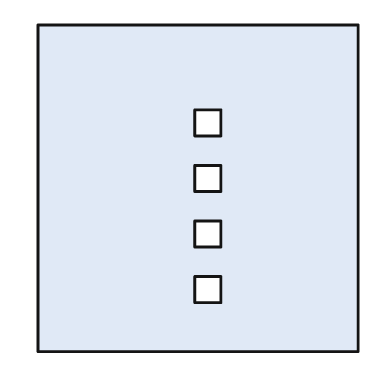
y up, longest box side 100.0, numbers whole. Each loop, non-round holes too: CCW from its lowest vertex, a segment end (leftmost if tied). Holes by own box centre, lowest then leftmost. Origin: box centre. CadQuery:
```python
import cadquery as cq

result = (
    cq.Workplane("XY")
    .moveTo(-49.0, -50.0)
    .lineTo(49.0, -50.0)
    .lineTo(49.0, 50.0)
    .lineTo(-49.0, 50.0)
    .close()
    .moveTo(-1.0, -35.0)
    .lineTo(7.0, -35.0)
    .lineTo(7.0, -27.0)
    .lineTo(-1.0, -27.0)
    .close()
    .moveTo(-1.0, -18.0)
    .lineTo(7.0, -18.0)
    .lineTo(7.0, -10.0)
    .lineTo(-1.0, -10.0)
    .close()
    .moveTo(-1.0, -1.0)
    .lineTo(7.0, -1.0)
    .lineTo(7.0, 7.0)
    .lineTo(-1.0, 7.0)
    .close()
    .moveTo(-1.0, 16.0)
    .lineTo(7.0, 16.0)
    .lineTo(7.0, 24.0)
    .lineTo(-1.0, 24.0)
    .close()
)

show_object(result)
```